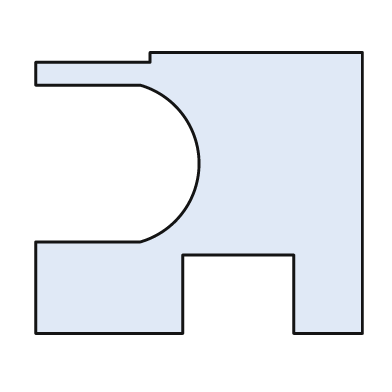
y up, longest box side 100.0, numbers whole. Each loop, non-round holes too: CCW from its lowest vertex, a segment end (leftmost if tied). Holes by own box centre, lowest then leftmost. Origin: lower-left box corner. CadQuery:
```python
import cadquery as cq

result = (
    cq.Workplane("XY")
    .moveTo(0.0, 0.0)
    .lineTo(45.0, 0.0)
    .lineTo(45.0, 24.0)
    .lineTo(79.0, 24.0)
    .lineTo(79.0, 0.0)
    .lineTo(100.0, 0.0)
    .lineTo(100.0, 86.0)
    .lineTo(35.0, 86.0)
    .lineTo(35.0, 83.0)
    .lineTo(0.0, 83.0)
    .lineTo(0.0, 76.0)
    .lineTo(32.0, 76.0)
    .threePointArc((50.0, 52.0), (32.0, 28.0))
    .lineTo(0.0, 28.0)
    .close()
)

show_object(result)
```